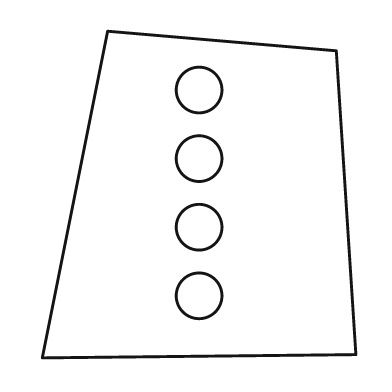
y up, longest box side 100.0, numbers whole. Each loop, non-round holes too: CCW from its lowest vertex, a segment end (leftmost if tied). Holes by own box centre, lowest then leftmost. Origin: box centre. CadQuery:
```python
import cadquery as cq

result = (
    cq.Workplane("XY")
    .moveTo(-48.0, -50.0)
    .lineTo(48.0, -49.0)
    .lineTo(42.0, 44.0)
    .lineTo(-28.0, 50.0)
    .close()
    .moveTo(0.0, -31.0)
    .circle(7.0)
    .moveTo(0.0, -10.0)
    .circle(7.0)
    .moveTo(0.0, 11.0)
    .circle(7.0)
    .moveTo(0.0, 32.0)
    .circle(7.0)
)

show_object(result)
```